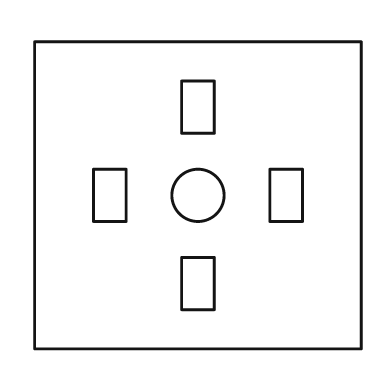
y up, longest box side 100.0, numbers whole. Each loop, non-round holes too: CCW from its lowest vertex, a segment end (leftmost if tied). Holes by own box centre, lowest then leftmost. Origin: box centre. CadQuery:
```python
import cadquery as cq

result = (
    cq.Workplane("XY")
    .moveTo(-50.0, -47.0)
    .lineTo(50.0, -47.0)
    .lineTo(50.0, 47.0)
    .lineTo(-50.0, 47.0)
    .close()
    .moveTo(-5.0, -35.0)
    .lineTo(5.0, -35.0)
    .lineTo(5.0, -19.0)
    .lineTo(-5.0, -19.0)
    .close()
    .moveTo(-32.0, -8.0)
    .lineTo(-22.0, -8.0)
    .lineTo(-22.0, 8.0)
    .lineTo(-32.0, 8.0)
    .close()
    .moveTo(0.0, 0.0)
    .circle(8.0)
    .moveTo(22.0, -8.0)
    .lineTo(32.0, -8.0)
    .lineTo(32.0, 8.0)
    .lineTo(22.0, 8.0)
    .close()
    .moveTo(-5.0, 19.0)
    .lineTo(5.0, 19.0)
    .lineTo(5.0, 35.0)
    .lineTo(-5.0, 35.0)
    .close()
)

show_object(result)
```